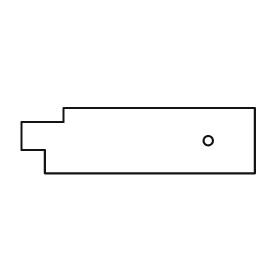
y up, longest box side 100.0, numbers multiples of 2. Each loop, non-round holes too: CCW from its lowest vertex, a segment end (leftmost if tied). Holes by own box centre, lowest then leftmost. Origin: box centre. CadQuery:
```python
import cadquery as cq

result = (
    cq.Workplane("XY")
    .moveTo(-40.0, -14.0)
    .lineTo(50.0, -14.0)
    .lineTo(50.0, 14.0)
    .lineTo(-32.0, 14.0)
    .lineTo(-32.0, 8.0)
    .lineTo(-50.0, 8.0)
    .lineTo(-50.0, -4.0)
    .lineTo(-40.0, -4.0)
    .close()
    .moveTo(30.0, 0.0)
    .circle(2.0)
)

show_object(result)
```